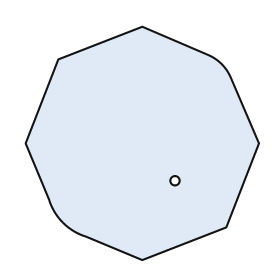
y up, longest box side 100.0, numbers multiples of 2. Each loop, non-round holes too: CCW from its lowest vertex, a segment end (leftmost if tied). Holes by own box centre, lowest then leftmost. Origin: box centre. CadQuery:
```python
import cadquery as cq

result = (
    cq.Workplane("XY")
    .moveTo(0.0, -50.0)
    .lineTo(36.0, -36.0)
    .lineTo(50.0, 0.0)
    .lineTo(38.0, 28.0)
    .threePointArc((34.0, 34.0), (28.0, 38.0))
    .lineTo(0.0, 50.0)
    .lineTo(-36.0, 36.0)
    .lineTo(-50.0, 0.0)
    .lineTo(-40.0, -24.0)
    .threePointArc((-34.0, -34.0), (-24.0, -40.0))
    .close()
    .moveTo(14.0, -16.0)
    .circle(2.0)
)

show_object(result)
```